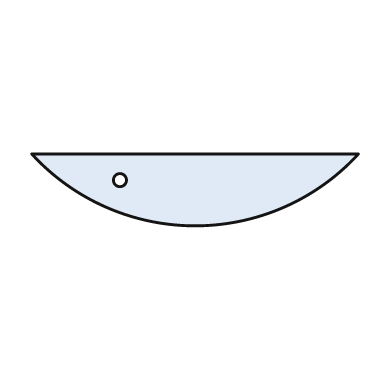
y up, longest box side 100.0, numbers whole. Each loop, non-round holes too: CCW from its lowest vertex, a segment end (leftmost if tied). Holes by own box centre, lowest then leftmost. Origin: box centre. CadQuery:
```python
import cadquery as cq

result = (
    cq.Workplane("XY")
    .moveTo(-50.0, 11.0)
    .threePointArc((0.0, -11.0), (50.0, 11.0))
    .close()
    .moveTo(-23.0, 3.0)
    .circle(2.0)
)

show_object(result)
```